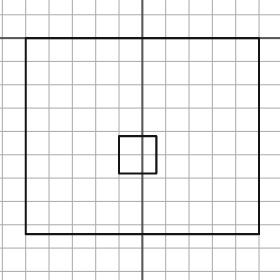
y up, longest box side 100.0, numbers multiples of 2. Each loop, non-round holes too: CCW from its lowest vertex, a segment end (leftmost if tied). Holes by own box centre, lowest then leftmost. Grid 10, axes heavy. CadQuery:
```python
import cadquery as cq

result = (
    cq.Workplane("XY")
    .moveTo(-50.0, -84.0)
    .lineTo(50.0, -84.0)
    .lineTo(50.0, 0.0)
    .lineTo(-50.0, 0.0)
    .close()
    .moveTo(-10.0, -58.0)
    .lineTo(6.0, -58.0)
    .lineTo(6.0, -42.0)
    .lineTo(-10.0, -42.0)
    .close()
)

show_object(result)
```